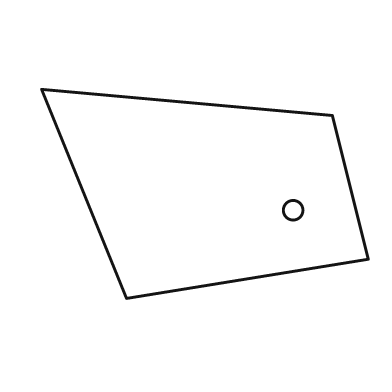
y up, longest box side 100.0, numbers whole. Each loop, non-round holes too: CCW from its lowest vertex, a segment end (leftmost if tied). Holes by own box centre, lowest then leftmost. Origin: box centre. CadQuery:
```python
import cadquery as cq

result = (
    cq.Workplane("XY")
    .moveTo(-24.0, -32.0)
    .lineTo(50.0, -20.0)
    .lineTo(39.0, 24.0)
    .lineTo(-50.0, 32.0)
    .close()
    .moveTo(27.0, -5.0)
    .circle(3.0)
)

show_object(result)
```